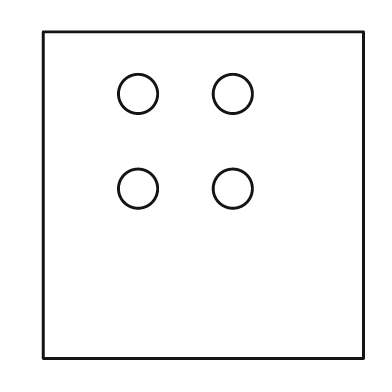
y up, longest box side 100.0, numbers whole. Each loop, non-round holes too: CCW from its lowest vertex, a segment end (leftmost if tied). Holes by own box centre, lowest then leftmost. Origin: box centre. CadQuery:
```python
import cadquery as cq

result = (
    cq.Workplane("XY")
    .moveTo(-49.0, -50.0)
    .lineTo(49.0, -50.0)
    .lineTo(49.0, 50.0)
    .lineTo(-49.0, 50.0)
    .close()
    .moveTo(-20.0, 2.0)
    .circle(6.0)
    .moveTo(9.0, 2.0)
    .circle(6.0)
    .moveTo(-20.0, 31.0)
    .circle(6.0)
    .moveTo(9.0, 31.0)
    .circle(6.0)
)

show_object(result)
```